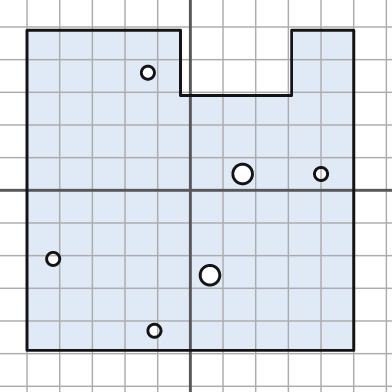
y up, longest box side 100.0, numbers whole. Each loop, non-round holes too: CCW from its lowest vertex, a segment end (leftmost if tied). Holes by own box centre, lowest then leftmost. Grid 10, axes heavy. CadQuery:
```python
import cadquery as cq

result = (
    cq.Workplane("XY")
    .moveTo(-50.0, -49.0)
    .lineTo(50.0, -49.0)
    .lineTo(50.0, 49.0)
    .lineTo(31.0, 49.0)
    .lineTo(31.0, 29.0)
    .lineTo(-3.0, 29.0)
    .lineTo(-3.0, 49.0)
    .lineTo(-50.0, 49.0)
    .close()
    .moveTo(-11.0, -43.0)
    .circle(2.0)
    .moveTo(6.0, -26.0)
    .circle(3.0)
    .moveTo(-42.0, -21.0)
    .circle(2.0)
    .moveTo(16.0, 5.0)
    .circle(3.0)
    .moveTo(40.0, 5.0)
    .circle(2.0)
    .moveTo(-13.0, 36.0)
    .circle(2.0)
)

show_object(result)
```